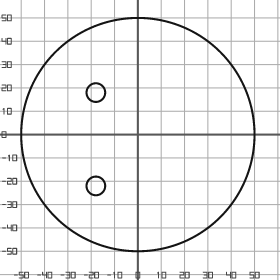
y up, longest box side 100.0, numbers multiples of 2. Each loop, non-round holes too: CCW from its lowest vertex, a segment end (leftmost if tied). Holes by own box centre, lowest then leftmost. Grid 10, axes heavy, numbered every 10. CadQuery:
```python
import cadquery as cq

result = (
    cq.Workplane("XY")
    .moveTo(0.0, 0.0)
    .circle(50.0)
    .moveTo(-18.0, -22.0)
    .circle(4.0)
    .moveTo(-18.0, 18.0)
    .circle(4.0)
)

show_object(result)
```